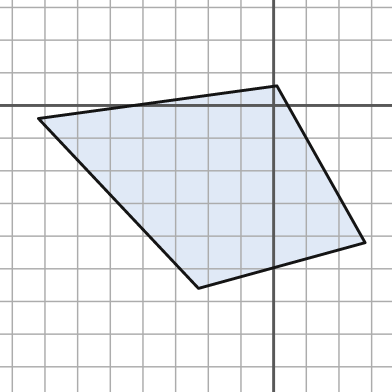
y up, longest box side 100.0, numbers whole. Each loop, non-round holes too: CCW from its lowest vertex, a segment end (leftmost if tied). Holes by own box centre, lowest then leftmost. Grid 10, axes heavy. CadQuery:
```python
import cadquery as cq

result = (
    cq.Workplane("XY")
    .moveTo(-23.0, -56.0)
    .lineTo(28.0, -42.0)
    .lineTo(1.0, 6.0)
    .lineTo(-72.0, -4.0)
    .close()
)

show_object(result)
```